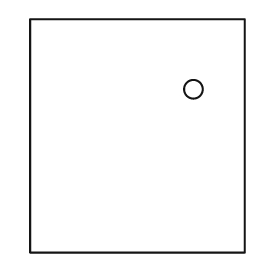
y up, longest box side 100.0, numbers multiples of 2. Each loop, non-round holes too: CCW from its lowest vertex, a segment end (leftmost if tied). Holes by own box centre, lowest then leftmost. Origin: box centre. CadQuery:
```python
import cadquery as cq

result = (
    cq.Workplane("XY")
    .moveTo(-46.0, -50.0)
    .lineTo(46.0, -50.0)
    .lineTo(46.0, 50.0)
    .lineTo(-46.0, 50.0)
    .close()
    .moveTo(24.0, 20.0)
    .circle(4.0)
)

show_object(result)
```